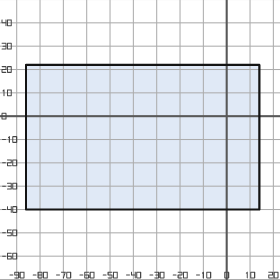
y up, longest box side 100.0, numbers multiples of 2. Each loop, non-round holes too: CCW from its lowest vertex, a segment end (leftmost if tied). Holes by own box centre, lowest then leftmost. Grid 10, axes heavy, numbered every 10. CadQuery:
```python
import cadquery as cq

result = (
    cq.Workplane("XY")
    .moveTo(-86.0, -40.0)
    .lineTo(14.0, -40.0)
    .lineTo(14.0, 22.0)
    .lineTo(-86.0, 22.0)
    .close()
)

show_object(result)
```